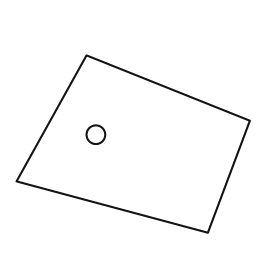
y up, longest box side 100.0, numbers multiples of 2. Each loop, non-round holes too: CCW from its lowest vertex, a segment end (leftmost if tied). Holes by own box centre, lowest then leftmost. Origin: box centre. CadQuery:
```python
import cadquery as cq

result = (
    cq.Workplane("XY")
    .moveTo(32.0, -38.0)
    .lineTo(50.0, 10.0)
    .lineTo(-20.0, 38.0)
    .lineTo(-50.0, -16.0)
    .close()
    .moveTo(-16.0, 4.0)
    .circle(4.0)
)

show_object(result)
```